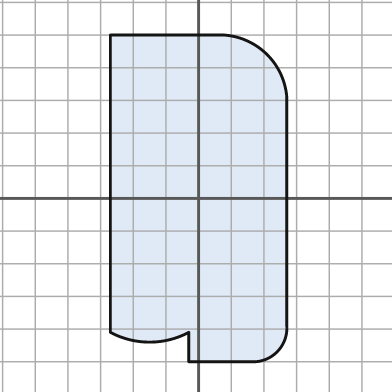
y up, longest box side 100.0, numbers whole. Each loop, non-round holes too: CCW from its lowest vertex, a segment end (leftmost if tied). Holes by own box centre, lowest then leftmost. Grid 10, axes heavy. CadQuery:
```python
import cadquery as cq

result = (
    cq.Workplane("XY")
    .moveTo(-3.0, -50.0)
    .lineTo(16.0, -50.0)
    .threePointArc((24.0, -47.0), (27.0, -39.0))
    .lineTo(27.0, 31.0)
    .threePointArc((21.0, 44.0), (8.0, 50.0))
    .lineTo(-27.0, 50.0)
    .lineTo(-27.0, -41.0)
    .threePointArc((-15.0, -44.0), (-3.0, -41.0))
    .close()
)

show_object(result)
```